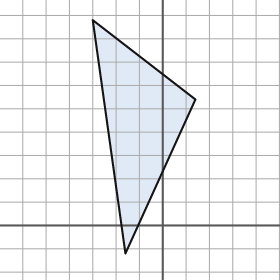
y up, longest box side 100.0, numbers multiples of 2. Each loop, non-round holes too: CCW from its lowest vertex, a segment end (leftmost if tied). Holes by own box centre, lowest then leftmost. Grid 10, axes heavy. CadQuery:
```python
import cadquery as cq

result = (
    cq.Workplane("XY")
    .moveTo(-16.0, -12.0)
    .lineTo(14.0, 54.0)
    .lineTo(-30.0, 88.0)
    .close()
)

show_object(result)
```